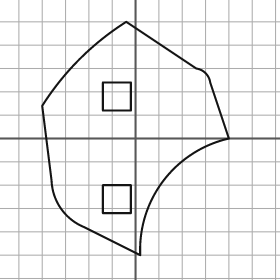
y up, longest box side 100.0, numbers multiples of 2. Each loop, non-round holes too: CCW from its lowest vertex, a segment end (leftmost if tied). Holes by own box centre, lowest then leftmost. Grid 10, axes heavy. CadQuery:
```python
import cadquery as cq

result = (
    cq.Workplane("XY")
    .moveTo(2.0, -50.0)
    .threePointArc((12.0, -18.0), (40.0, 0.0))
    .lineTo(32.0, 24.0)
    .threePointArc((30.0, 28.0), (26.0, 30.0))
    .lineTo(-4.0, 50.0)
    .threePointArc((-24.0, 34.0), (-40.0, 14.0))
    .lineTo(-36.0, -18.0)
    .threePointArc((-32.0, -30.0), (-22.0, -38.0))
    .close()
    .moveTo(-14.0, -32.0)
    .lineTo(-2.0, -32.0)
    .lineTo(-2.0, -20.0)
    .lineTo(-14.0, -20.0)
    .close()
    .moveTo(-14.0, 12.0)
    .lineTo(-2.0, 12.0)
    .lineTo(-2.0, 24.0)
    .lineTo(-14.0, 24.0)
    .close()
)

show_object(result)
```